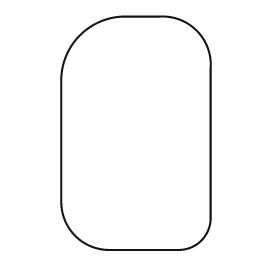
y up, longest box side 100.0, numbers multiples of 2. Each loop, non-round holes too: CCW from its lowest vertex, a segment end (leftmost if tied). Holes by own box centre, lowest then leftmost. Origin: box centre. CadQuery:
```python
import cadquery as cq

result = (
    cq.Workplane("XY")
    .moveTo(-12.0, -50.0)
    .lineTo(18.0, -50.0)
    .threePointArc((28.0, -46.0), (32.0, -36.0))
    .lineTo(32.0, 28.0)
    .threePointArc((26.0, 44.0), (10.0, 50.0))
    .lineTo(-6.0, 50.0)
    .threePointArc((-24.0, 42.0), (-32.0, 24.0))
    .lineTo(-32.0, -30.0)
    .threePointArc((-26.0, -44.0), (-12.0, -50.0))
    .close()
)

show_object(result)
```